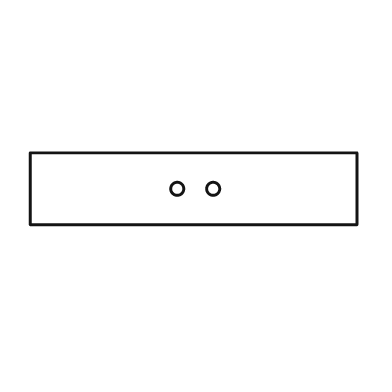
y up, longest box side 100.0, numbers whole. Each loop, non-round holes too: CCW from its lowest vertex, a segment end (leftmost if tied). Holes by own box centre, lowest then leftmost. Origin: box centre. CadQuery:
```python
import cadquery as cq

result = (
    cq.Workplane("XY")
    .moveTo(-50.0, -11.0)
    .lineTo(50.0, -11.0)
    .lineTo(50.0, 11.0)
    .lineTo(-50.0, 11.0)
    .close()
    .moveTo(-5.0, 0.0)
    .circle(2.0)
    .moveTo(6.0, 0.0)
    .circle(2.0)
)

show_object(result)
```